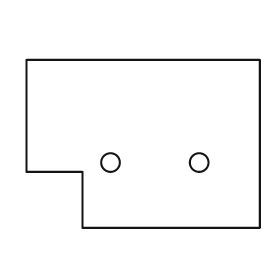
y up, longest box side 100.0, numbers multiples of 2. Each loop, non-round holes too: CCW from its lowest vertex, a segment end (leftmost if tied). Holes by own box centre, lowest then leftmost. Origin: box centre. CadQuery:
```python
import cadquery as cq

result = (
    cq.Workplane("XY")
    .moveTo(-26.0, -36.0)
    .lineTo(50.0, -36.0)
    .lineTo(50.0, 36.0)
    .lineTo(-50.0, 36.0)
    .lineTo(-50.0, -12.0)
    .lineTo(-26.0, -12.0)
    .close()
    .moveTo(-14.0, -8.0)
    .circle(4.0)
    .moveTo(24.0, -8.0)
    .circle(4.0)
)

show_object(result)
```